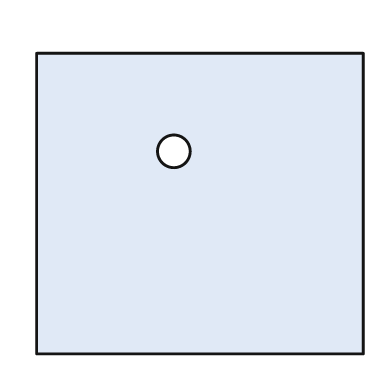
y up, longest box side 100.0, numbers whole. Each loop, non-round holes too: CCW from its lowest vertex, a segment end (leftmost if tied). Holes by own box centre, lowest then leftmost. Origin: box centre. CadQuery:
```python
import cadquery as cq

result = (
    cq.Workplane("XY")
    .moveTo(-50.0, -46.0)
    .lineTo(50.0, -46.0)
    .lineTo(50.0, 46.0)
    .lineTo(-50.0, 46.0)
    .close()
    .moveTo(-8.0, 16.0)
    .circle(5.0)
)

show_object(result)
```